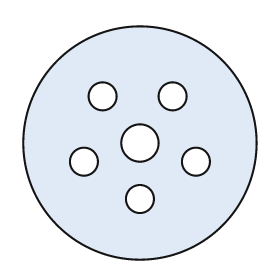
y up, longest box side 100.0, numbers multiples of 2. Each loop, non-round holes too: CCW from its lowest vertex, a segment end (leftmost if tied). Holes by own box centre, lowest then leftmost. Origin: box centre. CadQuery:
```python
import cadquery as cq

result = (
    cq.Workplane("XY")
    .moveTo(0.0, 0.0)
    .circle(50.0)
    .moveTo(0.0, -24.0)
    .circle(6.0)
    .moveTo(-24.0, -8.0)
    .circle(6.0)
    .moveTo(24.0, -8.0)
    .circle(6.0)
    .moveTo(0.0, 0.0)
    .circle(8.0)
    .moveTo(-16.0, 20.0)
    .circle(6.0)
    .moveTo(14.0, 20.0)
    .circle(6.0)
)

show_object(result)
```